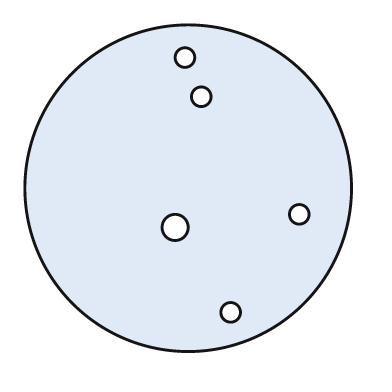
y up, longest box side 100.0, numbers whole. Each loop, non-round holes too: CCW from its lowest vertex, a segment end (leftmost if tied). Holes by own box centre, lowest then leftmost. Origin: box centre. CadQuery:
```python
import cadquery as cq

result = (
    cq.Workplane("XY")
    .moveTo(0.0, 0.0)
    .circle(50.0)
    .moveTo(13.0, -38.0)
    .circle(3.0)
    .moveTo(-4.0, -12.0)
    .circle(4.0)
    .moveTo(34.0, -8.0)
    .circle(3.0)
    .moveTo(4.0, 28.0)
    .circle(3.0)
    .moveTo(-1.0, 40.0)
    .circle(3.0)
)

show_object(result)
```